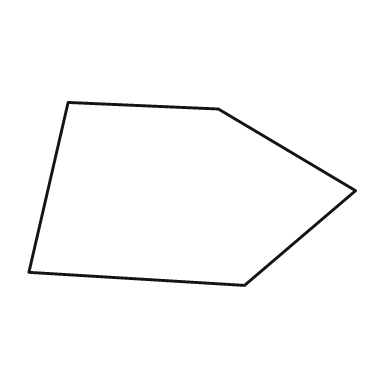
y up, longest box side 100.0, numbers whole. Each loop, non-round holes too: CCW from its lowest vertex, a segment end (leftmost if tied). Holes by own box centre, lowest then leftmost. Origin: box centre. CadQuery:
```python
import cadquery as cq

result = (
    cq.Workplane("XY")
    .moveTo(16.0, -28.0)
    .lineTo(50.0, 1.0)
    .lineTo(8.0, 26.0)
    .lineTo(-38.0, 28.0)
    .lineTo(-50.0, -24.0)
    .close()
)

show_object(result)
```